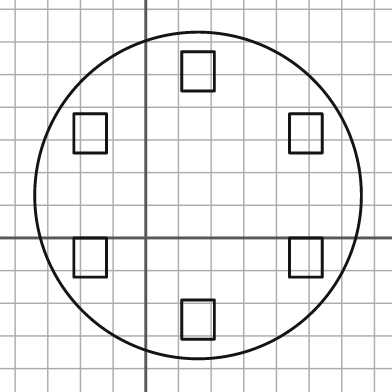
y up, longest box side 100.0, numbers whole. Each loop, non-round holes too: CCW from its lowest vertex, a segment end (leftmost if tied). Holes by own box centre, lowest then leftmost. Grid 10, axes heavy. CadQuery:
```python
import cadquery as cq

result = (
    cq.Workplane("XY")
    .moveTo(16.0, 13.0)
    .circle(50.0)
    .moveTo(11.0, -31.0)
    .lineTo(21.0, -31.0)
    .lineTo(21.0, -19.0)
    .lineTo(11.0, -19.0)
    .close()
    .moveTo(-22.0, -12.0)
    .lineTo(-12.0, -12.0)
    .lineTo(-12.0, 0.0)
    .lineTo(-22.0, 0.0)
    .close()
    .moveTo(44.0, -12.0)
    .lineTo(54.0, -12.0)
    .lineTo(54.0, 0.0)
    .lineTo(44.0, 0.0)
    .close()
    .moveTo(-22.0, 26.0)
    .lineTo(-12.0, 26.0)
    .lineTo(-12.0, 38.0)
    .lineTo(-22.0, 38.0)
    .close()
    .moveTo(44.0, 26.0)
    .lineTo(54.0, 26.0)
    .lineTo(54.0, 38.0)
    .lineTo(44.0, 38.0)
    .close()
    .moveTo(11.0, 45.0)
    .lineTo(21.0, 45.0)
    .lineTo(21.0, 57.0)
    .lineTo(11.0, 57.0)
    .close()
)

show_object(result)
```